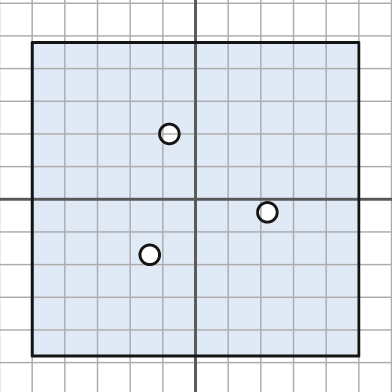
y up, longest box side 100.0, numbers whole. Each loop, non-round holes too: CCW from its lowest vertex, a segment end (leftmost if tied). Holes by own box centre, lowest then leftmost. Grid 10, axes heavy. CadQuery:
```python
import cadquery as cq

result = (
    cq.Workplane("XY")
    .moveTo(-50.0, -48.0)
    .lineTo(50.0, -48.0)
    .lineTo(50.0, 48.0)
    .lineTo(-50.0, 48.0)
    .close()
    .moveTo(-14.0, -17.0)
    .circle(3.0)
    .moveTo(22.0, -4.0)
    .circle(3.0)
    .moveTo(-8.0, 20.0)
    .circle(3.0)
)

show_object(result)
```